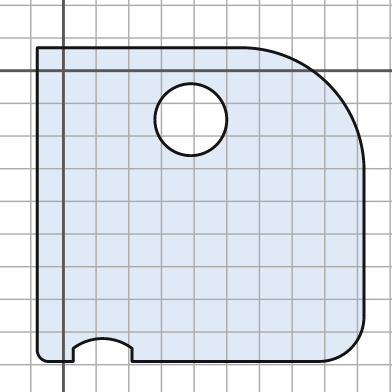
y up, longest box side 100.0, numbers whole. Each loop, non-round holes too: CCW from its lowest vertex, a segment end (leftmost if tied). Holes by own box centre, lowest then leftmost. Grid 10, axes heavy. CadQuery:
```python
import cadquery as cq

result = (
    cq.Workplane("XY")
    .moveTo(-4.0, -89.0)
    .lineTo(3.0, -89.0)
    .lineTo(3.0, -85.0)
    .threePointArc((12.0, -82.0), (21.0, -85.0))
    .lineTo(21.0, -89.0)
    .lineTo(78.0, -89.0)
    .threePointArc((88.0, -85.0), (92.0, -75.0))
    .lineTo(92.0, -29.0)
    .threePointArc((81.0, -4.0), (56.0, 7.0))
    .lineTo(-8.0, 7.0)
    .lineTo(-8.0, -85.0)
    .threePointArc((-7.0, -88.0), (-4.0, -89.0))
    .close()
    .moveTo(39.0, -15.0)
    .circle(11.0)
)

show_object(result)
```